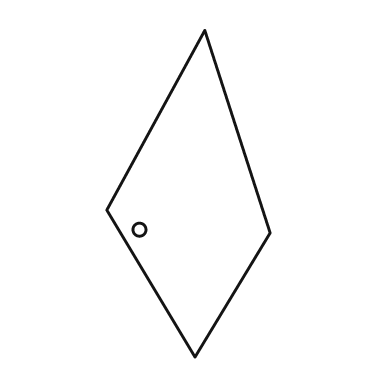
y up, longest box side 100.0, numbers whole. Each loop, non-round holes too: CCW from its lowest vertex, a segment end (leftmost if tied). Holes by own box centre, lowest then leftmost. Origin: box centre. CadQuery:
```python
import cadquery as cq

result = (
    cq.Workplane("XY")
    .moveTo(2.0, -50.0)
    .lineTo(25.0, -12.0)
    .lineTo(5.0, 50.0)
    .lineTo(-25.0, -5.0)
    .close()
    .moveTo(-15.0, -11.0)
    .circle(2.0)
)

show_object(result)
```